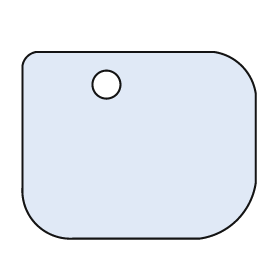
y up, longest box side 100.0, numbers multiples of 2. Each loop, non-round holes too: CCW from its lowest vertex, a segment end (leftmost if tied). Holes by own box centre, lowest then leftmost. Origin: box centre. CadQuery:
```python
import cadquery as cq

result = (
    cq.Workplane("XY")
    .moveTo(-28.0, -40.0)
    .lineTo(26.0, -40.0)
    .threePointArc((42.0, -32.0), (50.0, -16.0))
    .lineTo(50.0, 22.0)
    .threePointArc((44.0, 34.0), (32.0, 40.0))
    .lineTo(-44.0, 40.0)
    .threePointArc((-48.0, 38.0), (-50.0, 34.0))
    .lineTo(-50.0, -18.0)
    .threePointArc((-44.0, -34.0), (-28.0, -40.0))
    .close()
    .moveTo(-14.0, 26.0)
    .circle(6.0)
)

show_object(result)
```